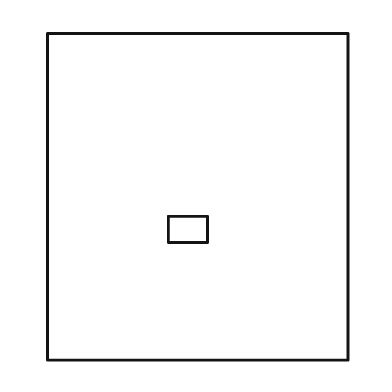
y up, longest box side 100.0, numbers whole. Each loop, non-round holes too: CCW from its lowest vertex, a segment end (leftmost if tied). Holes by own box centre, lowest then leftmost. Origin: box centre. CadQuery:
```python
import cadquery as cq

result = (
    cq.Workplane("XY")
    .moveTo(-46.0, -50.0)
    .lineTo(46.0, -50.0)
    .lineTo(46.0, 50.0)
    .lineTo(-46.0, 50.0)
    .close()
    .moveTo(-9.0, -14.0)
    .lineTo(3.0, -14.0)
    .lineTo(3.0, -6.0)
    .lineTo(-9.0, -6.0)
    .close()
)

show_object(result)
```